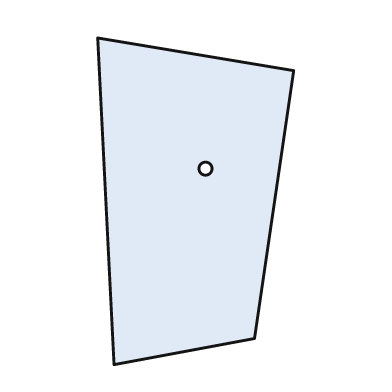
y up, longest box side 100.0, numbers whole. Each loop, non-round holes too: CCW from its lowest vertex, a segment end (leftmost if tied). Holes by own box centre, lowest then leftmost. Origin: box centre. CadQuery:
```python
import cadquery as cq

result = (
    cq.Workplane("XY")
    .moveTo(-25.0, -50.0)
    .lineTo(18.0, -42.0)
    .lineTo(30.0, 40.0)
    .lineTo(-30.0, 50.0)
    .close()
    .moveTo(3.0, 10.0)
    .circle(2.0)
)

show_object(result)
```